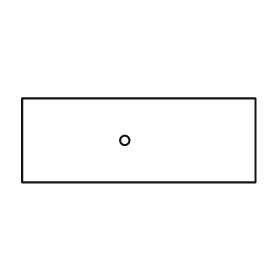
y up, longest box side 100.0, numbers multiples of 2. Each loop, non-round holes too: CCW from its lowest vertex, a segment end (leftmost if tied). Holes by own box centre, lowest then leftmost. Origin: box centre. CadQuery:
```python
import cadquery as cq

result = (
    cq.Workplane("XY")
    .moveTo(-50.0, -18.0)
    .lineTo(50.0, -18.0)
    .lineTo(50.0, 18.0)
    .lineTo(-50.0, 18.0)
    .close()
    .moveTo(-6.0, 0.0)
    .circle(2.0)
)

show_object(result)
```